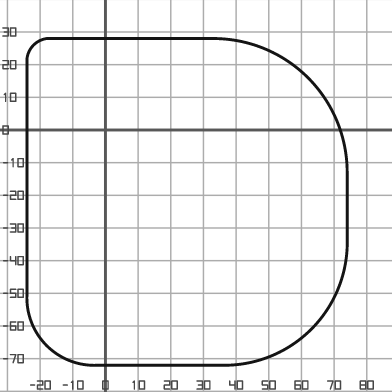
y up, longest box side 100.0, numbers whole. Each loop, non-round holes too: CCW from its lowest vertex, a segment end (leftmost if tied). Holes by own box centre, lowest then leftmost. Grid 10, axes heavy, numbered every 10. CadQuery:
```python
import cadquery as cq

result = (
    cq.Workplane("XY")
    .moveTo(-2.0, -72.0)
    .lineTo(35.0, -72.0)
    .threePointArc((63.0, -61.0), (74.0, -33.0))
    .lineTo(74.0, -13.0)
    .threePointArc((62.0, 16.0), (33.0, 28.0))
    .lineTo(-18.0, 28.0)
    .threePointArc((-22.0, 26.0), (-24.0, 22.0))
    .lineTo(-24.0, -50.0)
    .threePointArc((-18.0, -66.0), (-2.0, -72.0))
    .close()
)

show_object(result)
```